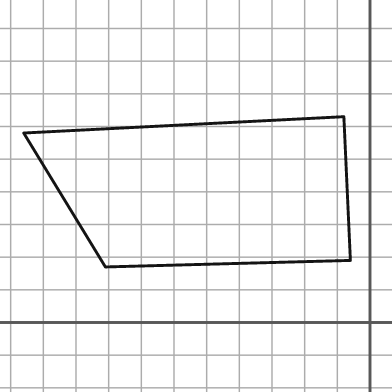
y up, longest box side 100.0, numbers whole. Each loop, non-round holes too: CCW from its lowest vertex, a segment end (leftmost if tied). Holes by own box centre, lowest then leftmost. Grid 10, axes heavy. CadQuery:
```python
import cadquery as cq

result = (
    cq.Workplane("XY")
    .moveTo(-81.0, 17.0)
    .lineTo(-6.0, 19.0)
    .lineTo(-8.0, 63.0)
    .lineTo(-106.0, 58.0)
    .close()
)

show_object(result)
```